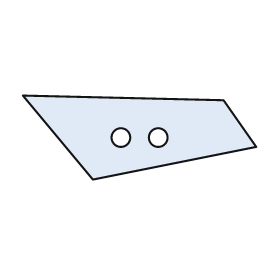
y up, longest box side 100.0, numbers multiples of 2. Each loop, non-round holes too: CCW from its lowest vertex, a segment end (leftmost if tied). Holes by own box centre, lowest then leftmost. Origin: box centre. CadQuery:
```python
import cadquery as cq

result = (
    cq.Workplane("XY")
    .moveTo(-20.0, -18.0)
    .lineTo(50.0, -4.0)
    .lineTo(36.0, 16.0)
    .lineTo(-50.0, 18.0)
    .close()
    .moveTo(-8.0, 0.0)
    .circle(4.0)
    .moveTo(8.0, 0.0)
    .circle(4.0)
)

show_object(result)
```